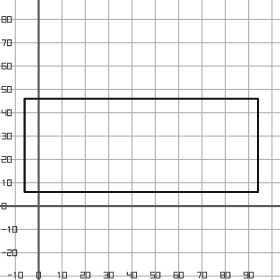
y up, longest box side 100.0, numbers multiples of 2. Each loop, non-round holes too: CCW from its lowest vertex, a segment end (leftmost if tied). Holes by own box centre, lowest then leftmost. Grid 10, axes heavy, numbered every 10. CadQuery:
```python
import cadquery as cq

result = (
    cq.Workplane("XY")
    .moveTo(-6.0, 6.0)
    .lineTo(94.0, 6.0)
    .lineTo(94.0, 46.0)
    .lineTo(-6.0, 46.0)
    .close()
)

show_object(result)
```